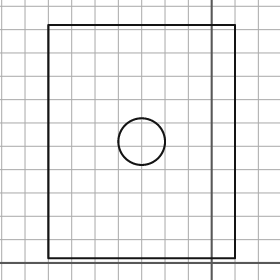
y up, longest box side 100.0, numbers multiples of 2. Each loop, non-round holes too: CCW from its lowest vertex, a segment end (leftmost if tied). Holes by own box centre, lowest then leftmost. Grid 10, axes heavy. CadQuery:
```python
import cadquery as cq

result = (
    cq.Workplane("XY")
    .moveTo(-70.0, 2.0)
    .lineTo(10.0, 2.0)
    .lineTo(10.0, 102.0)
    .lineTo(-70.0, 102.0)
    .close()
    .moveTo(-30.0, 52.0)
    .circle(10.0)
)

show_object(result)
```